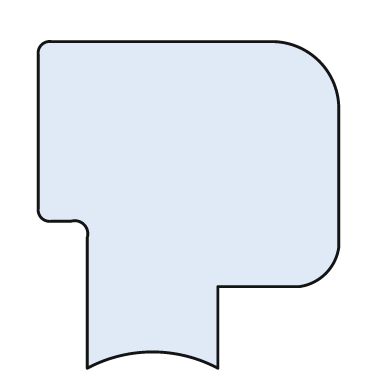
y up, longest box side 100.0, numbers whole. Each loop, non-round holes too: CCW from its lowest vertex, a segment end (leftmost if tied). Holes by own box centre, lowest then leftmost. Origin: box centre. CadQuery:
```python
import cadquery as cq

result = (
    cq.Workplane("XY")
    .moveTo(-31.0, -50.0)
    .threePointArc((-11.0, -45.0), (9.0, -50.0))
    .lineTo(9.0, -25.0)
    .lineTo(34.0, -25.0)
    .threePointArc((42.0, -21.0), (46.0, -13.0))
    .lineTo(46.0, 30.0)
    .threePointArc((40.0, 44.0), (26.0, 50.0))
    .lineTo(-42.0, 50.0)
    .threePointArc((-45.0, 49.0), (-46.0, 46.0))
    .lineTo(-46.0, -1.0)
    .threePointArc((-45.0, -4.0), (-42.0, -5.0))
    .lineTo(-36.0, -5.0)
    .threePointArc((-32.0, -6.0), (-31.0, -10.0))
    .close()
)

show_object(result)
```